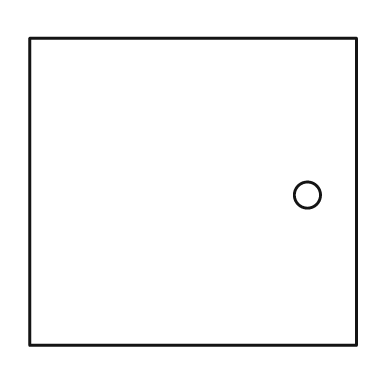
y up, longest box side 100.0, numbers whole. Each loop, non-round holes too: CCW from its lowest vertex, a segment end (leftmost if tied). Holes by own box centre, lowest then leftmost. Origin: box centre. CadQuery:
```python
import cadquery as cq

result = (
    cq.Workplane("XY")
    .moveTo(-50.0, -47.0)
    .lineTo(50.0, -47.0)
    .lineTo(50.0, 47.0)
    .lineTo(-50.0, 47.0)
    .close()
    .moveTo(35.0, -1.0)
    .circle(4.0)
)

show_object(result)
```